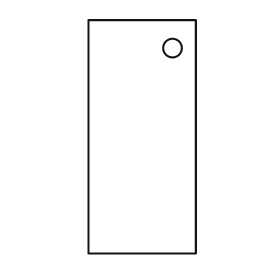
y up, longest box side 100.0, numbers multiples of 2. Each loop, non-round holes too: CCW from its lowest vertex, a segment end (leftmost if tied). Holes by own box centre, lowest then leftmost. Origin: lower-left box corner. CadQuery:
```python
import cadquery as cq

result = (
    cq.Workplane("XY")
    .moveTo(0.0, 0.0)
    .lineTo(46.0, 0.0)
    .lineTo(46.0, 100.0)
    .lineTo(0.0, 100.0)
    .close()
    .moveTo(36.0, 88.0)
    .circle(4.0)
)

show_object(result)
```